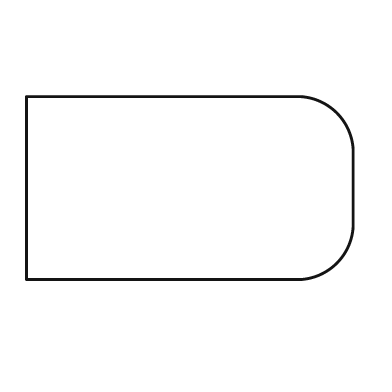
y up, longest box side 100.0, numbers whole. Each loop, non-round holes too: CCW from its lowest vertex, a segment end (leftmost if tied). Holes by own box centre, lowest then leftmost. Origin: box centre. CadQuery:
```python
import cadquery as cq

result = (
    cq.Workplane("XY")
    .moveTo(-50.0, -28.0)
    .lineTo(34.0, -28.0)
    .threePointArc((45.0, -23.0), (50.0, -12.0))
    .lineTo(50.0, 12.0)
    .threePointArc((45.0, 23.0), (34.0, 28.0))
    .lineTo(-50.0, 28.0)
    .close()
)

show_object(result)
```